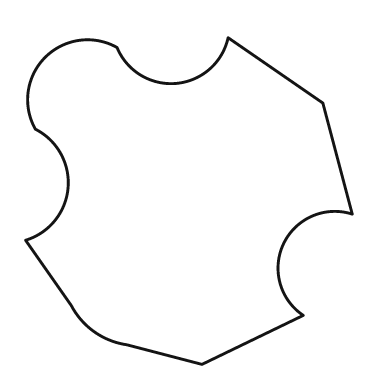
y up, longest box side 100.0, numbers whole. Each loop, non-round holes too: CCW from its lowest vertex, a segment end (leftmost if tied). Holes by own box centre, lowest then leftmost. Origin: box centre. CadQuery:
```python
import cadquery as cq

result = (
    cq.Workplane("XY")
    .moveTo(4.0, -50.0)
    .lineTo(35.0, -35.0)
    .threePointArc((29.0, -13.0), (50.0, -4.0))
    .lineTo(41.0, 30.0)
    .lineTo(12.0, 50.0)
    .threePointArc((-4.0, 36.0), (-22.0, 47.0))
    .threePointArc((-44.0, 44.0), (-47.0, 22.0))
    .threePointArc((-37.0, 4.0), (-50.0, -12.0))
    .lineTo(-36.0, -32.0)
    .threePointArc((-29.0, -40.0), (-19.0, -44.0))
    .close()
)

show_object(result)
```